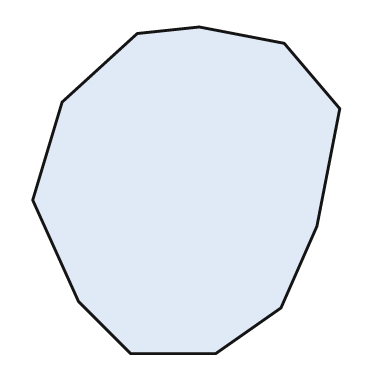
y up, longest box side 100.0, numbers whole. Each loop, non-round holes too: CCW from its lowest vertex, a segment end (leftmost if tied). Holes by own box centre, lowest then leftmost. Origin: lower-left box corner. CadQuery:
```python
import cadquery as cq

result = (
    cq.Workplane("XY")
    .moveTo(30.0, 0.0)
    .lineTo(56.0, 0.0)
    .lineTo(76.0, 14.0)
    .lineTo(87.0, 39.0)
    .lineTo(94.0, 75.0)
    .lineTo(77.0, 95.0)
    .lineTo(51.0, 100.0)
    .lineTo(32.0, 98.0)
    .lineTo(9.0, 77.0)
    .lineTo(0.0, 47.0)
    .lineTo(14.0, 16.0)
    .close()
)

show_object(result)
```